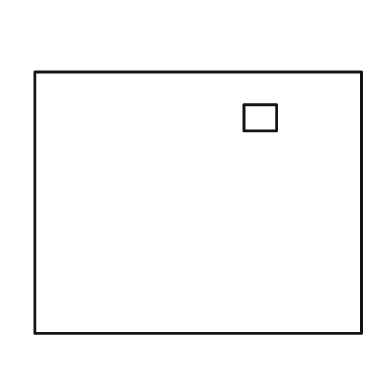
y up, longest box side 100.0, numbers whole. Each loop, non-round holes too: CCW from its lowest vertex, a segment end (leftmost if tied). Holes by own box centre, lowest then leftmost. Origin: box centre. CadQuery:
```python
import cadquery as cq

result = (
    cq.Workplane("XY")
    .moveTo(-50.0, -40.0)
    .lineTo(50.0, -40.0)
    .lineTo(50.0, 40.0)
    .lineTo(-50.0, 40.0)
    .close()
    .moveTo(14.0, 22.0)
    .lineTo(24.0, 22.0)
    .lineTo(24.0, 30.0)
    .lineTo(14.0, 30.0)
    .close()
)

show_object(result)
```